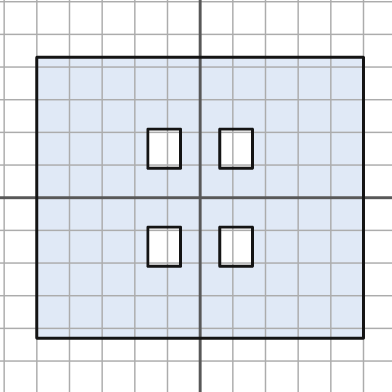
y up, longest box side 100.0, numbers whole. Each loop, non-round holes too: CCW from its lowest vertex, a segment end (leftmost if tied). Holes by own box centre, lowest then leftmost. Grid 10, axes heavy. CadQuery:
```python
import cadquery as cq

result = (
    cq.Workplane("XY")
    .moveTo(-50.0, -43.0)
    .lineTo(50.0, -43.0)
    .lineTo(50.0, 43.0)
    .lineTo(-50.0, 43.0)
    .close()
    .moveTo(-16.0, -21.0)
    .lineTo(-6.0, -21.0)
    .lineTo(-6.0, -9.0)
    .lineTo(-16.0, -9.0)
    .close()
    .moveTo(6.0, -21.0)
    .lineTo(16.0, -21.0)
    .lineTo(16.0, -9.0)
    .lineTo(6.0, -9.0)
    .close()
    .moveTo(-16.0, 9.0)
    .lineTo(-6.0, 9.0)
    .lineTo(-6.0, 21.0)
    .lineTo(-16.0, 21.0)
    .close()
    .moveTo(6.0, 9.0)
    .lineTo(16.0, 9.0)
    .lineTo(16.0, 21.0)
    .lineTo(6.0, 21.0)
    .close()
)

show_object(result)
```